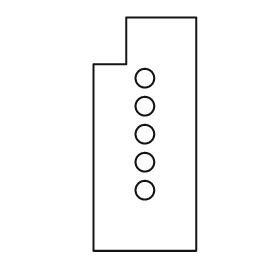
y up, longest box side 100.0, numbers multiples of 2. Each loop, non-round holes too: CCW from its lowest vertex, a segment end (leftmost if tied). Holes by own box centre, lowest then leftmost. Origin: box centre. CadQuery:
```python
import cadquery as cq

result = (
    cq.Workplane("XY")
    .moveTo(-22.0, -50.0)
    .lineTo(22.0, -50.0)
    .lineTo(22.0, 50.0)
    .lineTo(-8.0, 50.0)
    .lineTo(-8.0, 30.0)
    .lineTo(-22.0, 30.0)
    .close()
    .moveTo(0.0, -24.0)
    .circle(4.0)
    .moveTo(0.0, -12.0)
    .circle(4.0)
    .moveTo(0.0, 0.0)
    .circle(4.0)
    .moveTo(0.0, 12.0)
    .circle(4.0)
    .moveTo(0.0, 24.0)
    .circle(4.0)
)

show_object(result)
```